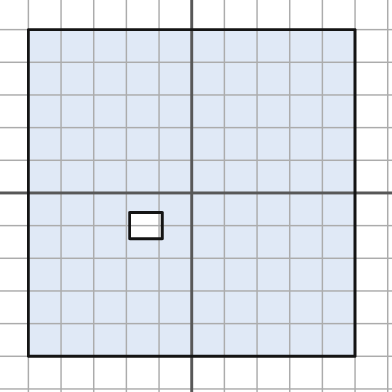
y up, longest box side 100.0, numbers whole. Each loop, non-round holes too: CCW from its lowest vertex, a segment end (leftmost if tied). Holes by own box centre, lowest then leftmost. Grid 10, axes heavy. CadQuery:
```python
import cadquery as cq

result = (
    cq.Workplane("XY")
    .moveTo(-50.0, -50.0)
    .lineTo(50.0, -50.0)
    .lineTo(50.0, 50.0)
    .lineTo(-50.0, 50.0)
    .close()
    .moveTo(-19.0, -14.0)
    .lineTo(-9.0, -14.0)
    .lineTo(-9.0, -6.0)
    .lineTo(-19.0, -6.0)
    .close()
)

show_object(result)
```